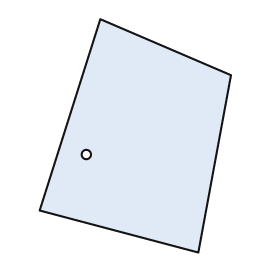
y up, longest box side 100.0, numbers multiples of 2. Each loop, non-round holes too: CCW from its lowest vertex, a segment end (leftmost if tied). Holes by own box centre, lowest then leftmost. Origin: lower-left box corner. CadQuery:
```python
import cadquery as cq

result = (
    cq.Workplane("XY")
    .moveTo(68.0, 0.0)
    .lineTo(82.0, 76.0)
    .lineTo(26.0, 100.0)
    .lineTo(0.0, 18.0)
    .close()
    .moveTo(20.0, 42.0)
    .circle(2.0)
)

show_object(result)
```